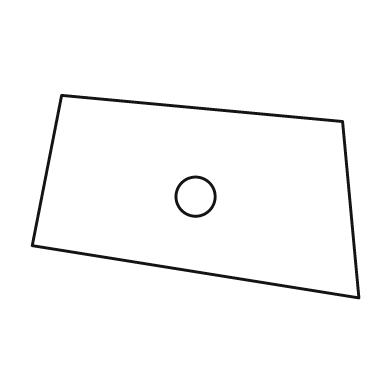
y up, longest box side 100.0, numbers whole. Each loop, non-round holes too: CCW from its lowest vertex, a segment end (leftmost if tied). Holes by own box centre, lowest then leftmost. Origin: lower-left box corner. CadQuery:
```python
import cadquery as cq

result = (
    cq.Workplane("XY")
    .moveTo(100.0, 0.0)
    .lineTo(95.0, 54.0)
    .lineTo(9.0, 62.0)
    .lineTo(0.0, 16.0)
    .close()
    .moveTo(50.0, 31.0)
    .circle(6.0)
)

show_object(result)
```